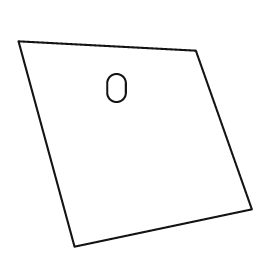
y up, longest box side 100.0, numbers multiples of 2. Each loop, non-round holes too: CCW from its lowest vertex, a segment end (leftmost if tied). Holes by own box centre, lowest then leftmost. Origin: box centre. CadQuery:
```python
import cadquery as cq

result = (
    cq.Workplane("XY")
    .moveTo(-26.0, -44.0)
    .lineTo(50.0, -28.0)
    .lineTo(26.0, 40.0)
    .lineTo(-50.0, 44.0)
    .close()
    .moveTo(-12.0, 22.0)
    .threePointArc((-8.0, 18.0), (-4.0, 22.0))
    .lineTo(-4.0, 26.0)
    .threePointArc((-8.0, 30.0), (-12.0, 26.0))
    .close()
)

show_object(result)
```